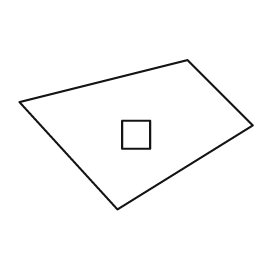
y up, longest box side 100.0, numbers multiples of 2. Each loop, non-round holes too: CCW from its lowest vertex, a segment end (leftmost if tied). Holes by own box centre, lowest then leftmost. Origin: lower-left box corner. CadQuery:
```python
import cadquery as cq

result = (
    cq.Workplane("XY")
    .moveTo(42.0, 0.0)
    .lineTo(100.0, 36.0)
    .lineTo(72.0, 64.0)
    .lineTo(0.0, 46.0)
    .close()
    .moveTo(44.0, 26.0)
    .lineTo(56.0, 26.0)
    .lineTo(56.0, 38.0)
    .lineTo(44.0, 38.0)
    .close()
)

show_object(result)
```